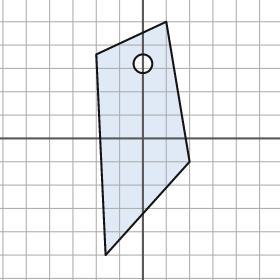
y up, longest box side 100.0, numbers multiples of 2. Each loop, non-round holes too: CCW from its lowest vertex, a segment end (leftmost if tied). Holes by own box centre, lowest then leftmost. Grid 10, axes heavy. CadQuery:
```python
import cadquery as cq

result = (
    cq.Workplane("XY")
    .moveTo(-16.0, -50.0)
    .lineTo(20.0, -10.0)
    .lineTo(10.0, 50.0)
    .lineTo(-20.0, 36.0)
    .close()
    .moveTo(0.0, 32.0)
    .circle(4.0)
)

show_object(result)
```